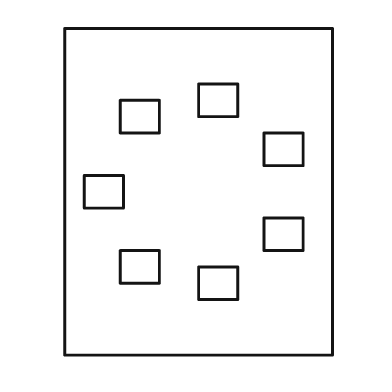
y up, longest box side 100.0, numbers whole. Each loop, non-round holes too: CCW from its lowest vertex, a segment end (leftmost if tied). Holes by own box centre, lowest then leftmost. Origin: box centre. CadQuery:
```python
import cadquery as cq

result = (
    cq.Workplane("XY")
    .moveTo(-41.0, -50.0)
    .lineTo(41.0, -50.0)
    .lineTo(41.0, 50.0)
    .lineTo(-41.0, 50.0)
    .close()
    .moveTo(0.0, -33.0)
    .lineTo(12.0, -33.0)
    .lineTo(12.0, -23.0)
    .lineTo(0.0, -23.0)
    .close()
    .moveTo(-24.0, -28.0)
    .lineTo(-12.0, -28.0)
    .lineTo(-12.0, -18.0)
    .lineTo(-24.0, -18.0)
    .close()
    .moveTo(20.0, -18.0)
    .lineTo(32.0, -18.0)
    .lineTo(32.0, -8.0)
    .lineTo(20.0, -8.0)
    .close()
    .moveTo(-35.0, -5.0)
    .lineTo(-23.0, -5.0)
    .lineTo(-23.0, 5.0)
    .lineTo(-35.0, 5.0)
    .close()
    .moveTo(20.0, 8.0)
    .lineTo(32.0, 8.0)
    .lineTo(32.0, 18.0)
    .lineTo(20.0, 18.0)
    .close()
    .moveTo(-24.0, 18.0)
    .lineTo(-12.0, 18.0)
    .lineTo(-12.0, 28.0)
    .lineTo(-24.0, 28.0)
    .close()
    .moveTo(0.0, 23.0)
    .lineTo(12.0, 23.0)
    .lineTo(12.0, 33.0)
    .lineTo(0.0, 33.0)
    .close()
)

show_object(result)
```